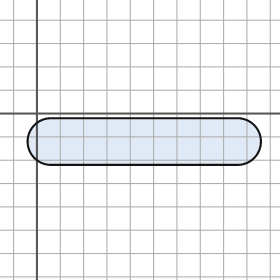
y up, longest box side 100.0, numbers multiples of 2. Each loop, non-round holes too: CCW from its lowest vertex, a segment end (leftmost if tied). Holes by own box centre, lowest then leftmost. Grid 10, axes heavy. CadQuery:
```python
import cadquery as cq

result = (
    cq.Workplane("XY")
    .moveTo(6.0, -22.0)
    .lineTo(86.0, -22.0)
    .threePointArc((96.0, -12.0), (86.0, -2.0))
    .lineTo(6.0, -2.0)
    .threePointArc((-4.0, -12.0), (6.0, -22.0))
    .close()
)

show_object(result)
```